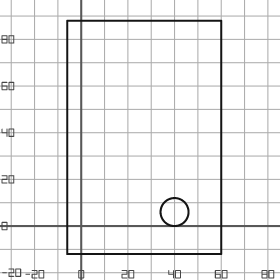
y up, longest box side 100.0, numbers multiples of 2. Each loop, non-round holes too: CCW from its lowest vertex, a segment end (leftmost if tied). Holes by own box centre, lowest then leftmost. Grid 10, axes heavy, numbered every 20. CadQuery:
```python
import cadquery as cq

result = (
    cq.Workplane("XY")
    .moveTo(-6.0, -12.0)
    .lineTo(60.0, -12.0)
    .lineTo(60.0, 88.0)
    .lineTo(-6.0, 88.0)
    .close()
    .moveTo(40.0, 6.0)
    .circle(6.0)
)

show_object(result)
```